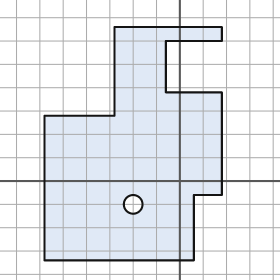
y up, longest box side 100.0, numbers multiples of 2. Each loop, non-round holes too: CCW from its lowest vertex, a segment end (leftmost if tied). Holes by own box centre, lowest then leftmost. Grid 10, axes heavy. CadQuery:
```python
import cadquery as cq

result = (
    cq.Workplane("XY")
    .moveTo(-58.0, -34.0)
    .lineTo(6.0, -34.0)
    .lineTo(6.0, -6.0)
    .lineTo(18.0, -6.0)
    .lineTo(18.0, 38.0)
    .lineTo(-6.0, 38.0)
    .lineTo(-6.0, 60.0)
    .lineTo(18.0, 60.0)
    .lineTo(18.0, 66.0)
    .lineTo(-28.0, 66.0)
    .lineTo(-28.0, 28.0)
    .lineTo(-58.0, 28.0)
    .close()
    .moveTo(-20.0, -10.0)
    .circle(4.0)
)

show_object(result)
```